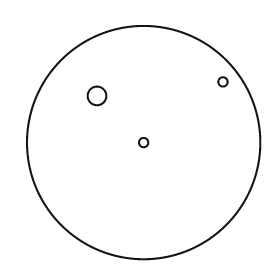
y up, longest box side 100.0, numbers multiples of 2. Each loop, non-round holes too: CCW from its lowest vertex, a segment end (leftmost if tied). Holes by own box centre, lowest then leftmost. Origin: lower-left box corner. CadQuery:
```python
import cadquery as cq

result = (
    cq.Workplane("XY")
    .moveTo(50.0, 50.0)
    .circle(50.0)
    .moveTo(50.0, 50.0)
    .circle(2.0)
    .moveTo(30.0, 70.0)
    .circle(4.0)
    .moveTo(84.0, 76.0)
    .circle(2.0)
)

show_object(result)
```